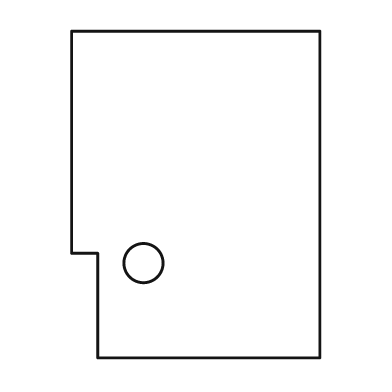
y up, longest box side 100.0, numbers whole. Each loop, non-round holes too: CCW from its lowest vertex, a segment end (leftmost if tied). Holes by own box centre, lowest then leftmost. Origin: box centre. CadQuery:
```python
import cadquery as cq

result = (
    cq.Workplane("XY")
    .moveTo(-30.0, -50.0)
    .lineTo(38.0, -50.0)
    .lineTo(38.0, 50.0)
    .lineTo(-38.0, 50.0)
    .lineTo(-38.0, -18.0)
    .lineTo(-30.0, -18.0)
    .close()
    .moveTo(-16.0, -21.0)
    .circle(6.0)
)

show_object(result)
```